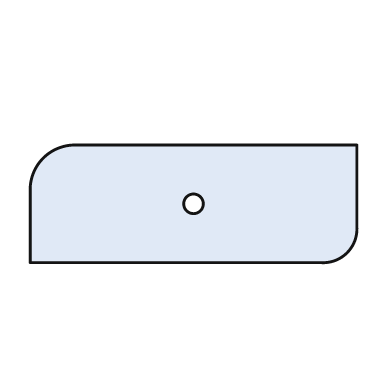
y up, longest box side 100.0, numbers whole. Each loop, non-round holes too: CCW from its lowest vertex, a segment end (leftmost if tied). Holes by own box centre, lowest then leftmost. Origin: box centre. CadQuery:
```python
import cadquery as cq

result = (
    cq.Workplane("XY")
    .moveTo(-50.0, -18.0)
    .lineTo(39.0, -18.0)
    .threePointArc((47.0, -15.0), (50.0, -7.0))
    .lineTo(50.0, 18.0)
    .lineTo(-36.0, 18.0)
    .threePointArc((-46.0, 14.0), (-50.0, 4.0))
    .close()
    .moveTo(0.0, 0.0)
    .circle(3.0)
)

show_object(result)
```